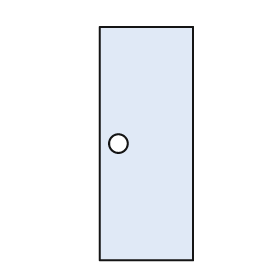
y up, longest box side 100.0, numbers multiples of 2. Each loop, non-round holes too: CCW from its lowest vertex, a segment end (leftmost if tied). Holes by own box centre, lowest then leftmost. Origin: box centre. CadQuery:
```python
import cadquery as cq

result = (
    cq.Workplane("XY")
    .moveTo(-20.0, -50.0)
    .lineTo(20.0, -50.0)
    .lineTo(20.0, 50.0)
    .lineTo(-20.0, 50.0)
    .close()
    .moveTo(-12.0, 0.0)
    .circle(4.0)
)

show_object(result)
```